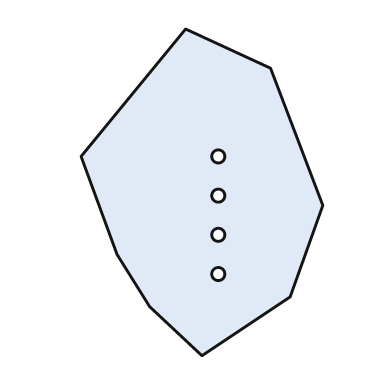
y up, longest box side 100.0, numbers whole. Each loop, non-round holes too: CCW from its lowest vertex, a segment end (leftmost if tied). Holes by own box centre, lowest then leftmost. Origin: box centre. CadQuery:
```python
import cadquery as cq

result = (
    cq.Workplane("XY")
    .moveTo(0.0, -50.0)
    .lineTo(27.0, -32.0)
    .lineTo(37.0, -4.0)
    .lineTo(21.0, 38.0)
    .lineTo(-5.0, 50.0)
    .lineTo(-37.0, 11.0)
    .lineTo(-26.0, -19.0)
    .lineTo(-16.0, -35.0)
    .close()
    .moveTo(5.0, -25.0)
    .circle(2.0)
    .moveTo(5.0, -13.0)
    .circle(2.0)
    .moveTo(5.0, -1.0)
    .circle(2.0)
    .moveTo(5.0, 11.0)
    .circle(2.0)
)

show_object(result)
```